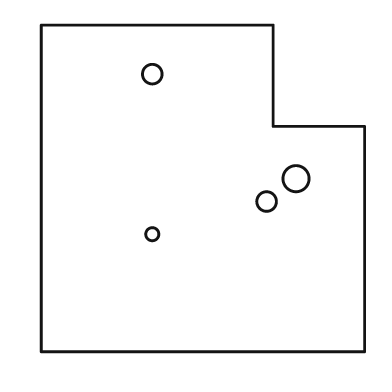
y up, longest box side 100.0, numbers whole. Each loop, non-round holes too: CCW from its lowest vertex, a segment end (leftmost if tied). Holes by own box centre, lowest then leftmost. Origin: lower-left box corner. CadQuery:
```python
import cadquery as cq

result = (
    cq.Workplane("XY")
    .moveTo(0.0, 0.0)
    .lineTo(99.0, 0.0)
    .lineTo(99.0, 69.0)
    .lineTo(71.0, 69.0)
    .lineTo(71.0, 100.0)
    .lineTo(0.0, 100.0)
    .close()
    .moveTo(34.0, 36.0)
    .circle(2.0)
    .moveTo(69.0, 46.0)
    .circle(3.0)
    .moveTo(78.0, 53.0)
    .circle(4.0)
    .moveTo(34.0, 85.0)
    .circle(3.0)
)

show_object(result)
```